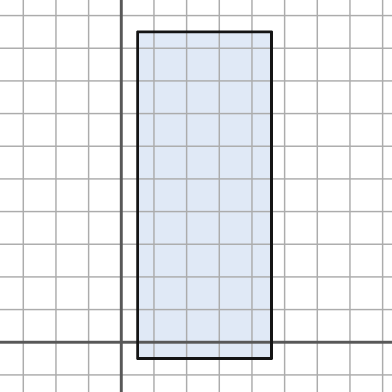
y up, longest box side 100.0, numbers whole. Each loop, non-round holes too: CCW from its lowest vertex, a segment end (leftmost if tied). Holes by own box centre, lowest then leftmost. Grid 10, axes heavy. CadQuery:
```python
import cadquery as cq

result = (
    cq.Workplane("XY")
    .moveTo(5.0, -5.0)
    .lineTo(46.0, -5.0)
    .lineTo(46.0, 95.0)
    .lineTo(5.0, 95.0)
    .close()
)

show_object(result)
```